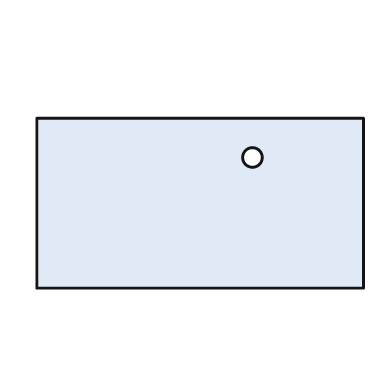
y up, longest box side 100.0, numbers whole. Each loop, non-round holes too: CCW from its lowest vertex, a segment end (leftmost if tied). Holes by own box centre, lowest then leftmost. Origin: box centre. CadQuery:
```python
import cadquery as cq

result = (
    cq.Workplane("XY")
    .moveTo(-50.0, -26.0)
    .lineTo(50.0, -26.0)
    .lineTo(50.0, 26.0)
    .lineTo(-50.0, 26.0)
    .close()
    .moveTo(16.0, 14.0)
    .circle(3.0)
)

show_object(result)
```